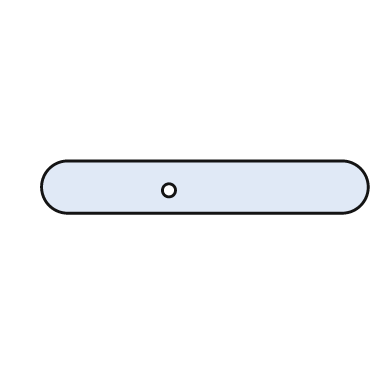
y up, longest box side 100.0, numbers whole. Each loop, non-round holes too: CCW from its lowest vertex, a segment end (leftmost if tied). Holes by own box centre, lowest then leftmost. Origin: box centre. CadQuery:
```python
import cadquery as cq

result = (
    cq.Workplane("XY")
    .moveTo(-42.0, -8.0)
    .lineTo(42.0, -8.0)
    .threePointArc((50.0, 0.0), (42.0, 8.0))
    .lineTo(-42.0, 8.0)
    .threePointArc((-50.0, 0.0), (-42.0, -8.0))
    .close()
    .moveTo(-11.0, -1.0)
    .circle(2.0)
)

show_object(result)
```